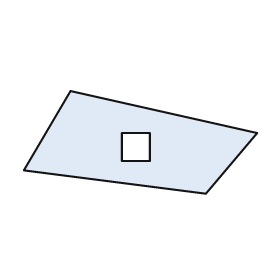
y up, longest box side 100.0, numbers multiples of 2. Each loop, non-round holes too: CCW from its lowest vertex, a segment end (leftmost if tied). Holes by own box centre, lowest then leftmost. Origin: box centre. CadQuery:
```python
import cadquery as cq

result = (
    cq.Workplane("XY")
    .moveTo(28.0, -22.0)
    .lineTo(50.0, 4.0)
    .lineTo(-30.0, 22.0)
    .lineTo(-50.0, -12.0)
    .close()
    .moveTo(-8.0, -8.0)
    .lineTo(4.0, -8.0)
    .lineTo(4.0, 4.0)
    .lineTo(-8.0, 4.0)
    .close()
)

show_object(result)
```